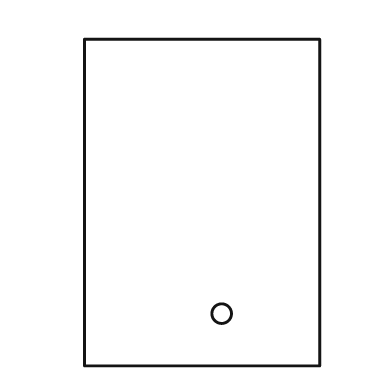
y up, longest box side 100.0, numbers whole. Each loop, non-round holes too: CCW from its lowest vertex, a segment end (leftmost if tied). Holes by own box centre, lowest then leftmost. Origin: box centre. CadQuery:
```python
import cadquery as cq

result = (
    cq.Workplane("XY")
    .moveTo(-36.0, -50.0)
    .lineTo(36.0, -50.0)
    .lineTo(36.0, 50.0)
    .lineTo(-36.0, 50.0)
    .close()
    .moveTo(6.0, -34.0)
    .circle(3.0)
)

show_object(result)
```